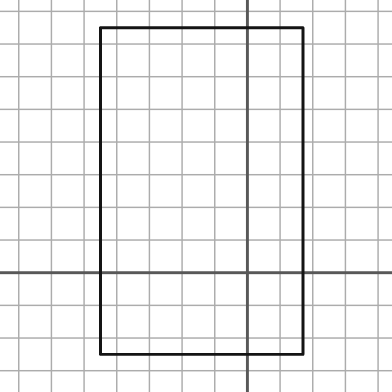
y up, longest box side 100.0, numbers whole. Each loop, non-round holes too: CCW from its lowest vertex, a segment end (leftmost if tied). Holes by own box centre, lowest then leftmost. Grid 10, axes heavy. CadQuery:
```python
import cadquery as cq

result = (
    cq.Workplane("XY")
    .moveTo(-45.0, -25.0)
    .lineTo(17.0, -25.0)
    .lineTo(17.0, 75.0)
    .lineTo(-45.0, 75.0)
    .close()
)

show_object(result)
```